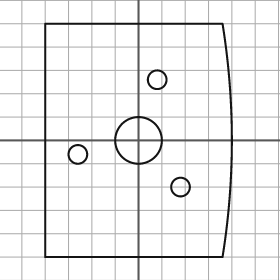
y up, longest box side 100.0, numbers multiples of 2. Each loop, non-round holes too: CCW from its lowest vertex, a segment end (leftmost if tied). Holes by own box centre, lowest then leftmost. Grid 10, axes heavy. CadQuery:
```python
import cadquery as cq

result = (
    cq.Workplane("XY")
    .moveTo(-40.0, -50.0)
    .lineTo(36.0, -50.0)
    .threePointArc((40.0, 0.0), (36.0, 50.0))
    .lineTo(-40.0, 50.0)
    .close()
    .moveTo(18.0, -20.0)
    .circle(4.0)
    .moveTo(-26.0, -6.0)
    .circle(4.0)
    .moveTo(0.0, 0.0)
    .circle(10.0)
    .moveTo(8.0, 26.0)
    .circle(4.0)
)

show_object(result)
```